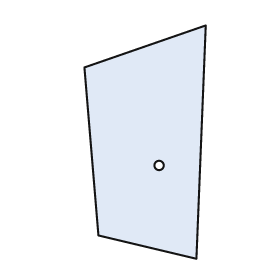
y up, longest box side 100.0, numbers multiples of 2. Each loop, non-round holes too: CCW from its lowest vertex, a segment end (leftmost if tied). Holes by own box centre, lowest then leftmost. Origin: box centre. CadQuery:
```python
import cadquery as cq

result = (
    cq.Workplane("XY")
    .moveTo(22.0, -50.0)
    .lineTo(26.0, 50.0)
    .lineTo(-26.0, 32.0)
    .lineTo(-20.0, -40.0)
    .close()
    .moveTo(6.0, -10.0)
    .circle(2.0)
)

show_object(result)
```